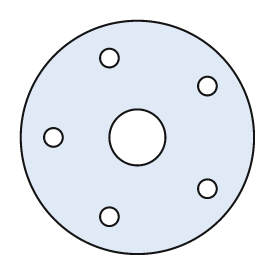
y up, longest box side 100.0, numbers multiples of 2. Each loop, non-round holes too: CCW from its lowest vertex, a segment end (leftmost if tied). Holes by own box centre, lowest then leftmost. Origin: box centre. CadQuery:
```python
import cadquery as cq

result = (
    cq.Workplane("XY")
    .moveTo(0.0, 0.0)
    .circle(50.0)
    .moveTo(-12.0, -34.0)
    .circle(4.0)
    .moveTo(30.0, -22.0)
    .circle(4.0)
    .moveTo(-36.0, 0.0)
    .circle(4.0)
    .moveTo(0.0, 0.0)
    .circle(12.0)
    .moveTo(30.0, 22.0)
    .circle(4.0)
    .moveTo(-12.0, 34.0)
    .circle(4.0)
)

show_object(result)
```